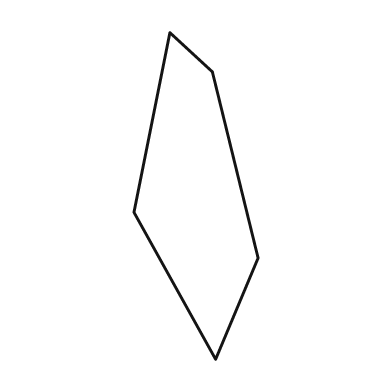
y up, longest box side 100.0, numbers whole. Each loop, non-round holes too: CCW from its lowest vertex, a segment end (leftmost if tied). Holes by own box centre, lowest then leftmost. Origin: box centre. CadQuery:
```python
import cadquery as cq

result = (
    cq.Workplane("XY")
    .moveTo(6.0, -50.0)
    .lineTo(19.0, -19.0)
    .lineTo(5.0, 38.0)
    .lineTo(-8.0, 50.0)
    .lineTo(-19.0, -5.0)
    .close()
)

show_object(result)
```